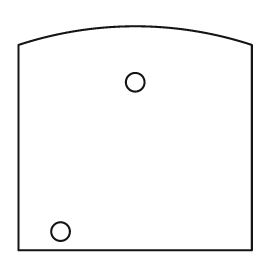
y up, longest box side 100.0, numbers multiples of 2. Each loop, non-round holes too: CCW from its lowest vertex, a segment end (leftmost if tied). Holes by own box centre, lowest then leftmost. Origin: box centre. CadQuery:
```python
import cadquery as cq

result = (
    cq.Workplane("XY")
    .moveTo(-50.0, -48.0)
    .lineTo(50.0, -48.0)
    .lineTo(50.0, 40.0)
    .threePointArc((0.0, 48.0), (-50.0, 40.0))
    .close()
    .moveTo(-32.0, -40.0)
    .circle(4.0)
    .moveTo(0.0, 24.0)
    .circle(4.0)
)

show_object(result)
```